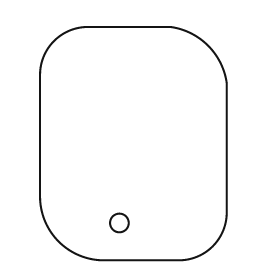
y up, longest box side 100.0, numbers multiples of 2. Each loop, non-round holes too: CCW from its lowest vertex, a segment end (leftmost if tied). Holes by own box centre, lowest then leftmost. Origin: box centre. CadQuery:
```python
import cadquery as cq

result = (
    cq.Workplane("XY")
    .moveTo(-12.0, -50.0)
    .lineTo(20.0, -50.0)
    .threePointArc((34.0, -44.0), (40.0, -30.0))
    .lineTo(40.0, 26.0)
    .threePointArc((32.0, 42.0), (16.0, 50.0))
    .lineTo(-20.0, 50.0)
    .threePointArc((-34.0, 44.0), (-40.0, 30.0))
    .lineTo(-40.0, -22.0)
    .threePointArc((-32.0, -42.0), (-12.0, -50.0))
    .close()
    .moveTo(-6.0, -34.0)
    .circle(4.0)
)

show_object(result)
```